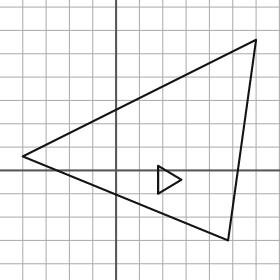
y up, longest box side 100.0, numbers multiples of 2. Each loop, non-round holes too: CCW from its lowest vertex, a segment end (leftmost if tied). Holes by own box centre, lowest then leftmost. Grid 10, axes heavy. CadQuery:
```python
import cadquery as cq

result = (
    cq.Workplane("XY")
    .moveTo(48.0, -30.0)
    .lineTo(60.0, 56.0)
    .lineTo(-40.0, 6.0)
    .close()
    .moveTo(18.0, -10.0)
    .lineTo(28.0, -4.0)
    .lineTo(18.0, 2.0)
    .close()
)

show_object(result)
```